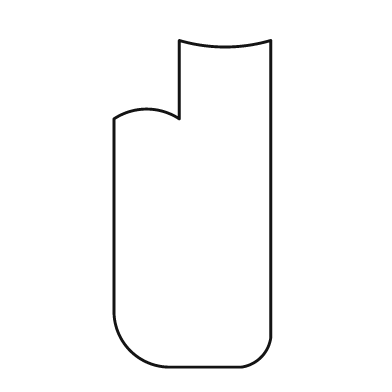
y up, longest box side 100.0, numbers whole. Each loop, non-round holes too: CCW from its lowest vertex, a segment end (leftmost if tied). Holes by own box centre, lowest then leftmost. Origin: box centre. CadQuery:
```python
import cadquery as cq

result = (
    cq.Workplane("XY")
    .moveTo(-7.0, -50.0)
    .lineTo(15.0, -50.0)
    .threePointArc((21.0, -47.0), (24.0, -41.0))
    .lineTo(24.0, 50.0)
    .threePointArc((10.0, 48.0), (-4.0, 50.0))
    .lineTo(-4.0, 26.0)
    .threePointArc((-14.0, 29.0), (-24.0, 26.0))
    .lineTo(-24.0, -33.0)
    .threePointArc((-19.0, -45.0), (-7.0, -50.0))
    .close()
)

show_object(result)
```